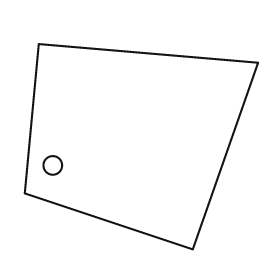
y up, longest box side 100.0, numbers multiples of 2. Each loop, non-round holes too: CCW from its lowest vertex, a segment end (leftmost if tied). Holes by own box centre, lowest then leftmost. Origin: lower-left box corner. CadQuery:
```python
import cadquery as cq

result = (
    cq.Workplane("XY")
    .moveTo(72.0, 0.0)
    .lineTo(100.0, 80.0)
    .lineTo(6.0, 88.0)
    .lineTo(0.0, 24.0)
    .close()
    .moveTo(12.0, 36.0)
    .circle(4.0)
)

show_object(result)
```